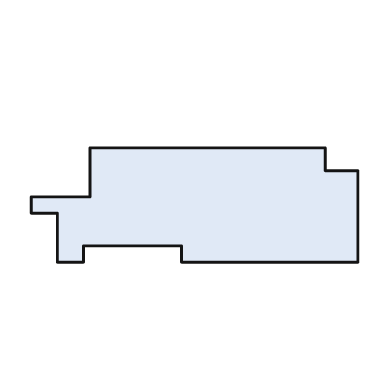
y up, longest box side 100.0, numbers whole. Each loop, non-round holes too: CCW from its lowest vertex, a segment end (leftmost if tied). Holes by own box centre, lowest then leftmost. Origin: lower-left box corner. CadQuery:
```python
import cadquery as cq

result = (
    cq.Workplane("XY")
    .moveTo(8.0, 0.0)
    .lineTo(16.0, 0.0)
    .lineTo(16.0, 5.0)
    .lineTo(46.0, 5.0)
    .lineTo(46.0, 0.0)
    .lineTo(100.0, 0.0)
    .lineTo(100.0, 28.0)
    .lineTo(90.0, 28.0)
    .lineTo(90.0, 35.0)
    .lineTo(18.0, 35.0)
    .lineTo(18.0, 20.0)
    .lineTo(0.0, 20.0)
    .lineTo(0.0, 15.0)
    .lineTo(8.0, 15.0)
    .close()
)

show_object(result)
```